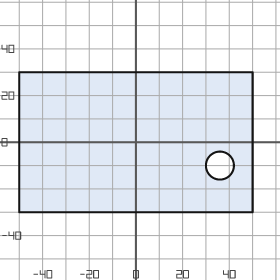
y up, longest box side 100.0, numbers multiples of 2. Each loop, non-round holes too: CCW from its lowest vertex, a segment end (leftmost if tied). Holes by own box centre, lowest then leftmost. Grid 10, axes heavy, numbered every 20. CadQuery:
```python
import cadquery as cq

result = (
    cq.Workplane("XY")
    .moveTo(-50.0, -30.0)
    .lineTo(50.0, -30.0)
    .lineTo(50.0, 30.0)
    .lineTo(-50.0, 30.0)
    .close()
    .moveTo(36.0, -10.0)
    .circle(6.0)
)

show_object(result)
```